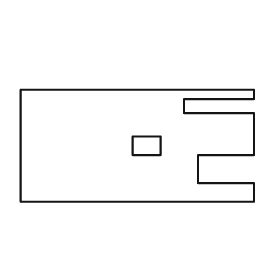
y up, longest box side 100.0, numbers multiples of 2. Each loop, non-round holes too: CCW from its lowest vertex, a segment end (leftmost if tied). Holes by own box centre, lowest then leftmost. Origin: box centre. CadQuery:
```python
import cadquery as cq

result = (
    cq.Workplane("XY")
    .moveTo(-50.0, -24.0)
    .lineTo(50.0, -24.0)
    .lineTo(50.0, -16.0)
    .lineTo(26.0, -16.0)
    .lineTo(26.0, -4.0)
    .lineTo(50.0, -4.0)
    .lineTo(50.0, 14.0)
    .lineTo(20.0, 14.0)
    .lineTo(20.0, 20.0)
    .lineTo(50.0, 20.0)
    .lineTo(50.0, 24.0)
    .lineTo(-50.0, 24.0)
    .close()
    .moveTo(-2.0, -4.0)
    .lineTo(10.0, -4.0)
    .lineTo(10.0, 4.0)
    .lineTo(-2.0, 4.0)
    .close()
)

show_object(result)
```